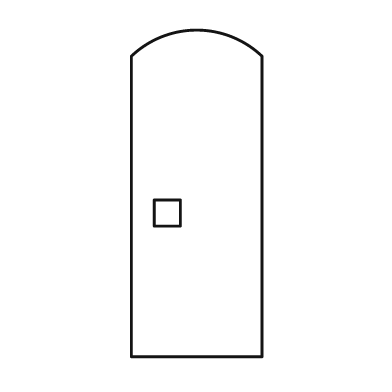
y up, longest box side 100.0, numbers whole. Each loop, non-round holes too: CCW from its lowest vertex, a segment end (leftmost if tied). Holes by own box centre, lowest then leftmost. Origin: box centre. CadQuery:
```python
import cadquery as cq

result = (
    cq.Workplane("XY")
    .moveTo(-20.0, -50.0)
    .lineTo(20.0, -50.0)
    .lineTo(20.0, 42.0)
    .threePointArc((0.0, 50.0), (-20.0, 42.0))
    .close()
    .moveTo(-13.0, -10.0)
    .lineTo(-5.0, -10.0)
    .lineTo(-5.0, -2.0)
    .lineTo(-13.0, -2.0)
    .close()
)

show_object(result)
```